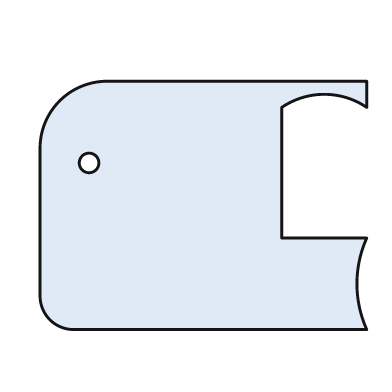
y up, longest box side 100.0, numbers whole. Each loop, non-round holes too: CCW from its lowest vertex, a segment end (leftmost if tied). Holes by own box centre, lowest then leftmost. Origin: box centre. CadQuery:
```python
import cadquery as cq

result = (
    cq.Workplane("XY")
    .moveTo(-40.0, -38.0)
    .lineTo(50.0, -38.0)
    .threePointArc((47.0, -24.0), (50.0, -10.0))
    .lineTo(24.0, -10.0)
    .lineTo(24.0, 30.0)
    .threePointArc((37.0, 34.0), (50.0, 30.0))
    .lineTo(50.0, 38.0)
    .lineTo(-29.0, 38.0)
    .threePointArc((-44.0, 32.0), (-50.0, 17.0))
    .lineTo(-50.0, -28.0)
    .threePointArc((-47.0, -35.0), (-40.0, -38.0))
    .close()
    .moveTo(-35.0, 13.0)
    .circle(3.0)
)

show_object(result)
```